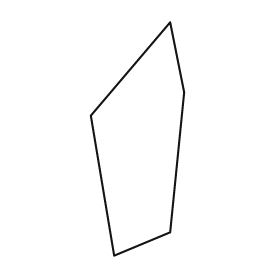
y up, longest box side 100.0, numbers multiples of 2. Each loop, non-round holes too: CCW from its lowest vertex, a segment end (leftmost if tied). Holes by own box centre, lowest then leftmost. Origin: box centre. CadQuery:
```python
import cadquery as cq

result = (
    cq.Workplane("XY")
    .moveTo(-10.0, -50.0)
    .lineTo(14.0, -40.0)
    .lineTo(20.0, 20.0)
    .lineTo(14.0, 50.0)
    .lineTo(-20.0, 10.0)
    .close()
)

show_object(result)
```